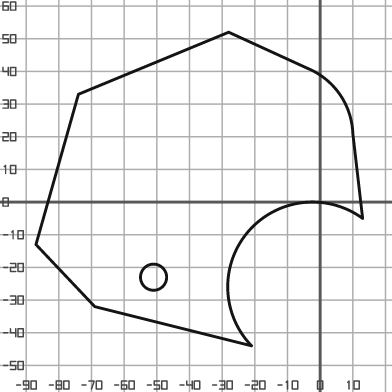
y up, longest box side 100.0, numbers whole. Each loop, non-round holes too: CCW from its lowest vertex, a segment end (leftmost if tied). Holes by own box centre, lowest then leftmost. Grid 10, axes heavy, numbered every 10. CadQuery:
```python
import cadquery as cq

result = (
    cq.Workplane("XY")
    .moveTo(-21.0, -44.0)
    .threePointArc((-22.0, -9.0), (13.0, -5.0))
    .lineTo(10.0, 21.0)
    .threePointArc((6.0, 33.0), (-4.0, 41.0))
    .lineTo(-28.0, 52.0)
    .lineTo(-74.0, 33.0)
    .lineTo(-87.0, -13.0)
    .lineTo(-69.0, -32.0)
    .close()
    .moveTo(-51.0, -23.0)
    .circle(4.0)
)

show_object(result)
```